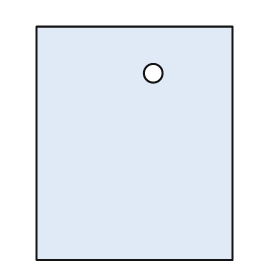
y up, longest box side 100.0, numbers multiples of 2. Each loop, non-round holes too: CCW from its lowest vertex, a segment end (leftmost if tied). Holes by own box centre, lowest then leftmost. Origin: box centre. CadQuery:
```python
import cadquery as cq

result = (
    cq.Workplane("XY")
    .moveTo(-42.0, -50.0)
    .lineTo(42.0, -50.0)
    .lineTo(42.0, 50.0)
    .lineTo(-42.0, 50.0)
    .close()
    .moveTo(8.0, 30.0)
    .circle(4.0)
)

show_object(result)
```